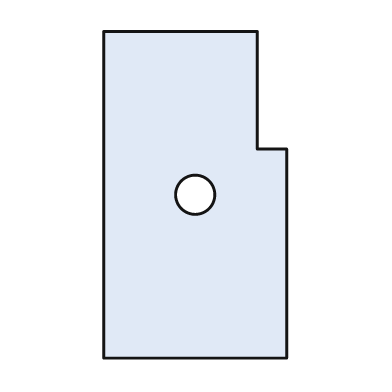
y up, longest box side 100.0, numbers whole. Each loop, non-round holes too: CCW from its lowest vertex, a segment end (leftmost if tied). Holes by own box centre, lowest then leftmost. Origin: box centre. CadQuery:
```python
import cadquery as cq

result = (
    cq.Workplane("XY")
    .moveTo(-28.0, -50.0)
    .lineTo(28.0, -50.0)
    .lineTo(28.0, 14.0)
    .lineTo(19.0, 14.0)
    .lineTo(19.0, 50.0)
    .lineTo(-28.0, 50.0)
    .close()
    .moveTo(0.0, 0.0)
    .circle(6.0)
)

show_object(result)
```